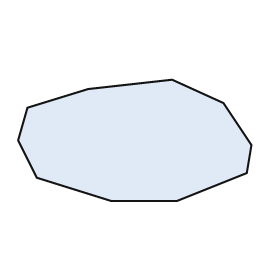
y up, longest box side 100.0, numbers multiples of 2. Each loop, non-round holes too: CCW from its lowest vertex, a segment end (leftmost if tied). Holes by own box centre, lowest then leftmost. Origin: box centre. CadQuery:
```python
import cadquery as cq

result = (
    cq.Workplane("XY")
    .moveTo(-10.0, -26.0)
    .lineTo(18.0, -26.0)
    .lineTo(48.0, -14.0)
    .lineTo(50.0, -2.0)
    .lineTo(38.0, 16.0)
    .lineTo(16.0, 26.0)
    .lineTo(-20.0, 22.0)
    .lineTo(-46.0, 14.0)
    .lineTo(-50.0, 0.0)
    .lineTo(-42.0, -16.0)
    .close()
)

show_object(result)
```